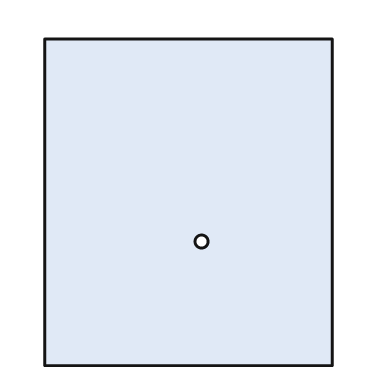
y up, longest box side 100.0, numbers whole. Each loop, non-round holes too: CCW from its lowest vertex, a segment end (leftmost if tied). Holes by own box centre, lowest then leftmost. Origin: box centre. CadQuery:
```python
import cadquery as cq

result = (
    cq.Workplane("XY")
    .moveTo(-44.0, -50.0)
    .lineTo(44.0, -50.0)
    .lineTo(44.0, 50.0)
    .lineTo(-44.0, 50.0)
    .close()
    .moveTo(4.0, -12.0)
    .circle(2.0)
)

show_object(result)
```